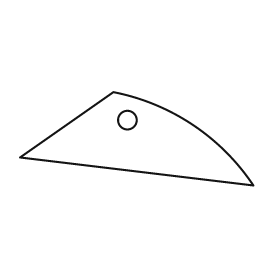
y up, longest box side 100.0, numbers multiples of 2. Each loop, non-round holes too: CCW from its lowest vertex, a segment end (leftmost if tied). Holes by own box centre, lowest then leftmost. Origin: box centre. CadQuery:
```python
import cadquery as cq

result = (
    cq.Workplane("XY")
    .moveTo(50.0, -20.0)
    .threePointArc((24.0, 6.0), (-10.0, 20.0))
    .lineTo(-50.0, -8.0)
    .close()
    .moveTo(-4.0, 8.0)
    .circle(4.0)
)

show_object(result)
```